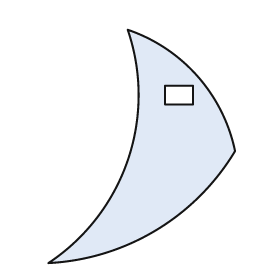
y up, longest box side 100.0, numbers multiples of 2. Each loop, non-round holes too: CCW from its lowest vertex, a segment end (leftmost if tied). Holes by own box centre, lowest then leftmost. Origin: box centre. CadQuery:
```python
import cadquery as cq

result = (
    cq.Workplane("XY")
    .moveTo(-40.0, -50.0)
    .threePointArc((6.0, -36.0), (40.0, -2.0))
    .threePointArc((24.0, 30.0), (-6.0, 50.0))
    .threePointArc((-6.0, -6.0), (-40.0, -50.0))
    .close()
    .moveTo(10.0, 18.0)
    .lineTo(22.0, 18.0)
    .lineTo(22.0, 26.0)
    .lineTo(10.0, 26.0)
    .close()
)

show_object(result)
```